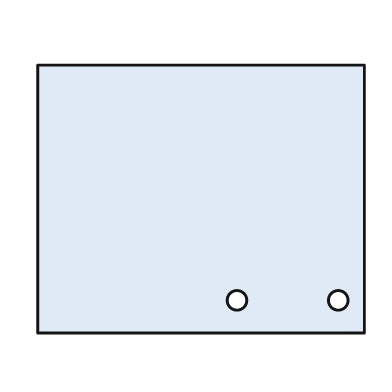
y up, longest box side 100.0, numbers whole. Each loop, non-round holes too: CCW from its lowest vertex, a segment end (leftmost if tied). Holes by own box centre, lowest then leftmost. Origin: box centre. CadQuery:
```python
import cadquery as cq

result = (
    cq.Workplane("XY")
    .moveTo(-50.0, -41.0)
    .lineTo(50.0, -41.0)
    .lineTo(50.0, 41.0)
    .lineTo(-50.0, 41.0)
    .close()
    .moveTo(11.0, -31.0)
    .circle(3.0)
    .moveTo(42.0, -31.0)
    .circle(3.0)
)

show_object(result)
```